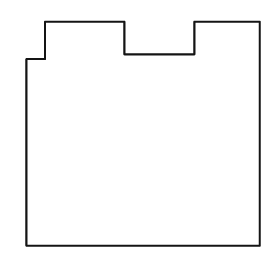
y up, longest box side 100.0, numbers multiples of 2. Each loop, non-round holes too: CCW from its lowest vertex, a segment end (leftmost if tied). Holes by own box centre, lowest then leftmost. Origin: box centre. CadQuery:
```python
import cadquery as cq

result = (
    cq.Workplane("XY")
    .moveTo(-50.0, -48.0)
    .lineTo(50.0, -48.0)
    .lineTo(50.0, 48.0)
    .lineTo(22.0, 48.0)
    .lineTo(22.0, 34.0)
    .lineTo(-8.0, 34.0)
    .lineTo(-8.0, 48.0)
    .lineTo(-42.0, 48.0)
    .lineTo(-42.0, 32.0)
    .lineTo(-50.0, 32.0)
    .close()
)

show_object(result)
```